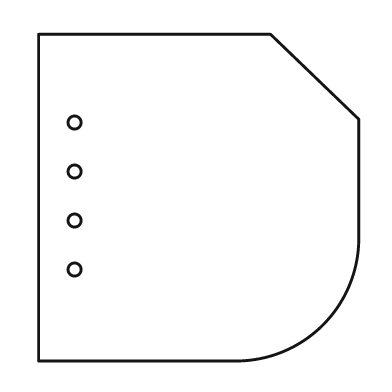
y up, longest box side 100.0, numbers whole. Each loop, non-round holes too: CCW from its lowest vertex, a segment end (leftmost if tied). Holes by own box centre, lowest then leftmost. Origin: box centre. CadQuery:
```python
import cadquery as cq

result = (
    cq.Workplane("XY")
    .moveTo(-49.0, -50.0)
    .lineTo(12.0, -50.0)
    .threePointArc((38.0, -39.0), (49.0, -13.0))
    .lineTo(49.0, 24.0)
    .lineTo(22.0, 50.0)
    .lineTo(-49.0, 50.0)
    .close()
    .moveTo(-38.0, -22.0)
    .circle(2.0)
    .moveTo(-38.0, -7.0)
    .circle(2.0)
    .moveTo(-38.0, 8.0)
    .circle(2.0)
    .moveTo(-38.0, 23.0)
    .circle(2.0)
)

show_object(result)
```